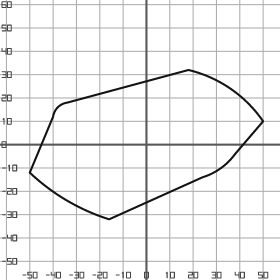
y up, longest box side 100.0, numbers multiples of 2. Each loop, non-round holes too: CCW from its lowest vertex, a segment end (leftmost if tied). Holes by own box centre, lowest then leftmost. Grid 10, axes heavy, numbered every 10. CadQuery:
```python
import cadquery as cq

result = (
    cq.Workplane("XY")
    .moveTo(-16.0, -32.0)
    .lineTo(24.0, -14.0)
    .threePointArc((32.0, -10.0), (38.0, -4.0))
    .lineTo(50.0, 10.0)
    .threePointArc((36.0, 24.0), (18.0, 32.0))
    .lineTo(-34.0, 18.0)
    .threePointArc((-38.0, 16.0), (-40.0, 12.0))
    .lineTo(-50.0, -12.0)
    .threePointArc((-34.0, -24.0), (-16.0, -32.0))
    .close()
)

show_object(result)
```